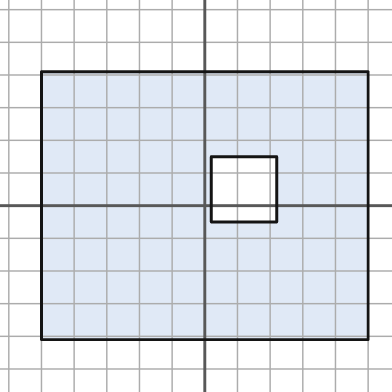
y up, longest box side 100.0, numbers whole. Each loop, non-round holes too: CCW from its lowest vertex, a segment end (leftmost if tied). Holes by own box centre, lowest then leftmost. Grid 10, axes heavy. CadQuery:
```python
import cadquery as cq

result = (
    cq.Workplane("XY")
    .moveTo(-50.0, -41.0)
    .lineTo(50.0, -41.0)
    .lineTo(50.0, 41.0)
    .lineTo(-50.0, 41.0)
    .close()
    .moveTo(2.0, -5.0)
    .lineTo(22.0, -5.0)
    .lineTo(22.0, 15.0)
    .lineTo(2.0, 15.0)
    .close()
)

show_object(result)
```